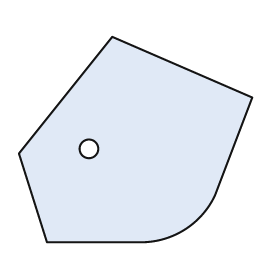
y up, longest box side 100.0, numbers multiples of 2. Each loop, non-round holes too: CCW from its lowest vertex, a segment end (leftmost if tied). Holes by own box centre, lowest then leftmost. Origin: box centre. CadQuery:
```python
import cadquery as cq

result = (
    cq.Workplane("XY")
    .moveTo(-38.0, -44.0)
    .lineTo(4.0, -44.0)
    .threePointArc((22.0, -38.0), (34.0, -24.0))
    .lineTo(50.0, 18.0)
    .lineTo(-10.0, 44.0)
    .lineTo(-50.0, -6.0)
    .close()
    .moveTo(-20.0, -4.0)
    .circle(4.0)
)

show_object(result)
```